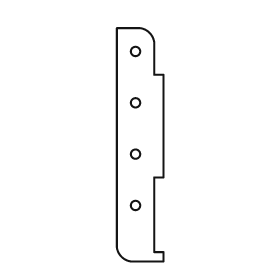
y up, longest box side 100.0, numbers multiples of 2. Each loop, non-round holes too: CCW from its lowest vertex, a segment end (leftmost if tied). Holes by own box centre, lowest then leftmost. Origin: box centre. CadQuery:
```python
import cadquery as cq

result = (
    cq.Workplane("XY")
    .moveTo(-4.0, -50.0)
    .lineTo(10.0, -50.0)
    .lineTo(10.0, -46.0)
    .lineTo(6.0, -46.0)
    .lineTo(6.0, -14.0)
    .lineTo(10.0, -14.0)
    .lineTo(10.0, 30.0)
    .lineTo(6.0, 30.0)
    .lineTo(6.0, 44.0)
    .threePointArc((4.0, 48.0), (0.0, 50.0))
    .lineTo(-10.0, 50.0)
    .lineTo(-10.0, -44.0)
    .threePointArc((-8.0, -48.0), (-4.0, -50.0))
    .close()
    .moveTo(-2.0, -26.0)
    .circle(2.0)
    .moveTo(-2.0, -4.0)
    .circle(2.0)
    .moveTo(-2.0, 18.0)
    .circle(2.0)
    .moveTo(-2.0, 40.0)
    .circle(2.0)
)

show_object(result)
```